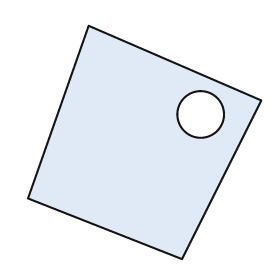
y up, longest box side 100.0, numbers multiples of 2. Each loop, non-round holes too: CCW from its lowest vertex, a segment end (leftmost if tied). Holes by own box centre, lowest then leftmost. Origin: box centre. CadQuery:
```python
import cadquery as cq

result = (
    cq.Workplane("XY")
    .moveTo(16.0, -50.0)
    .lineTo(50.0, 18.0)
    .lineTo(-24.0, 50.0)
    .lineTo(-50.0, -24.0)
    .close()
    .moveTo(24.0, 12.0)
    .circle(10.0)
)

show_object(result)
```